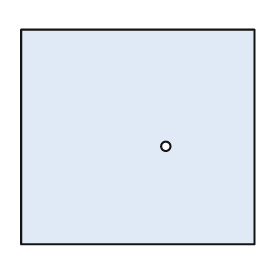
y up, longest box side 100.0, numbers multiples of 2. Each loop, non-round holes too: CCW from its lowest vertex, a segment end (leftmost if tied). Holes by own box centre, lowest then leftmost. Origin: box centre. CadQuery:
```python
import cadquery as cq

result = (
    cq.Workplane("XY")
    .moveTo(-50.0, -46.0)
    .lineTo(50.0, -46.0)
    .lineTo(50.0, 46.0)
    .lineTo(-50.0, 46.0)
    .close()
    .moveTo(12.0, -4.0)
    .circle(2.0)
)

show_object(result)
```